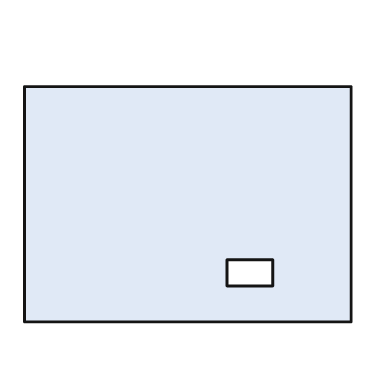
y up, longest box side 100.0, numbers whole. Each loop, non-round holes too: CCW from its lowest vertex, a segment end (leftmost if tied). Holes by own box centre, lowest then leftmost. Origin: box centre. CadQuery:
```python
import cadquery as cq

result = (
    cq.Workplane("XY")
    .moveTo(-50.0, -36.0)
    .lineTo(50.0, -36.0)
    .lineTo(50.0, 36.0)
    .lineTo(-50.0, 36.0)
    .close()
    .moveTo(12.0, -25.0)
    .lineTo(26.0, -25.0)
    .lineTo(26.0, -17.0)
    .lineTo(12.0, -17.0)
    .close()
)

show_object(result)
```